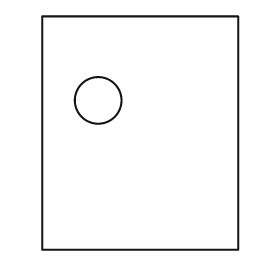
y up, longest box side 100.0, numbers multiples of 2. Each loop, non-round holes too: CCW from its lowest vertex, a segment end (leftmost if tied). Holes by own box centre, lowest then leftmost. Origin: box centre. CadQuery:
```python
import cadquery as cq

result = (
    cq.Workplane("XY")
    .moveTo(-42.0, -50.0)
    .lineTo(42.0, -50.0)
    .lineTo(42.0, 50.0)
    .lineTo(-42.0, 50.0)
    .close()
    .moveTo(-18.0, 14.0)
    .circle(10.0)
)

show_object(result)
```